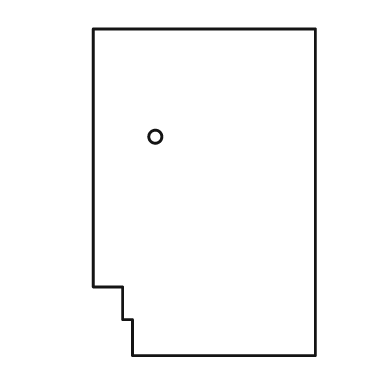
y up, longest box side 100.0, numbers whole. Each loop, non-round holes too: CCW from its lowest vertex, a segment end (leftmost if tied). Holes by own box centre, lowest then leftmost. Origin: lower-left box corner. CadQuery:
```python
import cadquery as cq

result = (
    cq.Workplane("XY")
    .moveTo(12.0, 0.0)
    .lineTo(68.0, 0.0)
    .lineTo(68.0, 100.0)
    .lineTo(0.0, 100.0)
    .lineTo(0.0, 21.0)
    .lineTo(9.0, 21.0)
    .lineTo(9.0, 11.0)
    .lineTo(12.0, 11.0)
    .close()
    .moveTo(19.0, 67.0)
    .circle(2.0)
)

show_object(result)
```